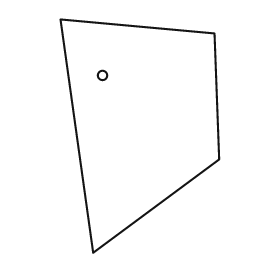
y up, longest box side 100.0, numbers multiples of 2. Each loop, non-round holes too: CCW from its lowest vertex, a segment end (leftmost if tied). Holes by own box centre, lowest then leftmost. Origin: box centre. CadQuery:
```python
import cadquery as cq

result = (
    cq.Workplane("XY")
    .moveTo(-20.0, -50.0)
    .lineTo(34.0, -10.0)
    .lineTo(32.0, 44.0)
    .lineTo(-34.0, 50.0)
    .close()
    .moveTo(-16.0, 26.0)
    .circle(2.0)
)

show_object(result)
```